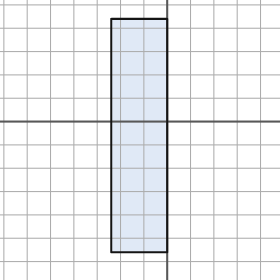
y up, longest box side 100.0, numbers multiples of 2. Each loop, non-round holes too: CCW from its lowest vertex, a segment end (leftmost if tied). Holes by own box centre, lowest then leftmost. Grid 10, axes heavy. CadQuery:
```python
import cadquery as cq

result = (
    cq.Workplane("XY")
    .moveTo(-24.0, -56.0)
    .lineTo(0.0, -56.0)
    .lineTo(0.0, 44.0)
    .lineTo(-24.0, 44.0)
    .close()
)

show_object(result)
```